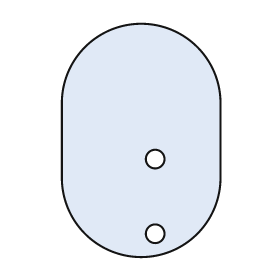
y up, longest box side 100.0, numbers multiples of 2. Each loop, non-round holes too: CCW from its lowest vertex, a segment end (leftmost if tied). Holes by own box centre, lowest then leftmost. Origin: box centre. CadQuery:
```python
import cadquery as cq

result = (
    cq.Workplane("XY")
    .moveTo(-34.0, -16.0)
    .threePointArc((0.0, -50.0), (34.0, -16.0))
    .lineTo(34.0, 16.0)
    .threePointArc((0.0, 50.0), (-34.0, 16.0))
    .close()
    .moveTo(6.0, -40.0)
    .circle(4.0)
    .moveTo(6.0, -8.0)
    .circle(4.0)
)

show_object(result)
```